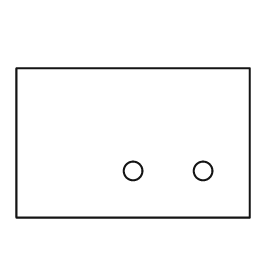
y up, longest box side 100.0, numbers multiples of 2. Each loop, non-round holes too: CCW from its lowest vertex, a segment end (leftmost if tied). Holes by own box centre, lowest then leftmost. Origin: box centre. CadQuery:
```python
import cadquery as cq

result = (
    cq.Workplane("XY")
    .moveTo(-50.0, -32.0)
    .lineTo(50.0, -32.0)
    .lineTo(50.0, 32.0)
    .lineTo(-50.0, 32.0)
    .close()
    .moveTo(0.0, -12.0)
    .circle(4.0)
    .moveTo(30.0, -12.0)
    .circle(4.0)
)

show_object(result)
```